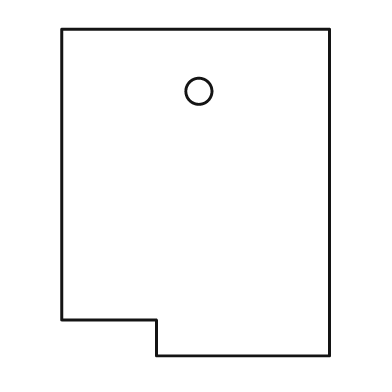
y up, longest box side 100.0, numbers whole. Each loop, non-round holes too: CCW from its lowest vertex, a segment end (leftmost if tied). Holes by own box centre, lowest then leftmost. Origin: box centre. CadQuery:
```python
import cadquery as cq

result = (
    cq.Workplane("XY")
    .moveTo(-12.0, -50.0)
    .lineTo(41.0, -50.0)
    .lineTo(41.0, 50.0)
    .lineTo(-41.0, 50.0)
    .lineTo(-41.0, -39.0)
    .lineTo(-12.0, -39.0)
    .close()
    .moveTo(1.0, 31.0)
    .circle(4.0)
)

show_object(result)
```